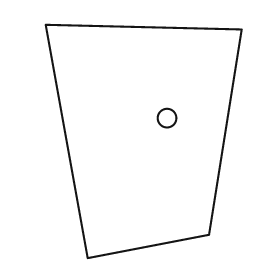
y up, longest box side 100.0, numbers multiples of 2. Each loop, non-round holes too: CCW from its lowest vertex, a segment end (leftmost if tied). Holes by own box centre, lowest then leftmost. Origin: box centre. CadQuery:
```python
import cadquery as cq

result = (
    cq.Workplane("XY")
    .moveTo(-24.0, -50.0)
    .lineTo(28.0, -40.0)
    .lineTo(42.0, 48.0)
    .lineTo(-42.0, 50.0)
    .close()
    .moveTo(10.0, 10.0)
    .circle(4.0)
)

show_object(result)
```